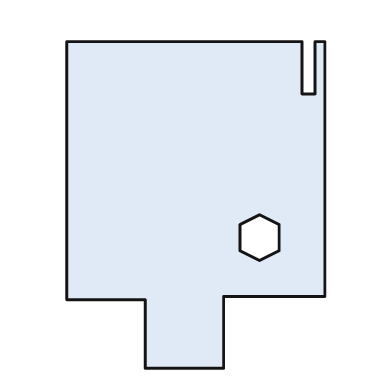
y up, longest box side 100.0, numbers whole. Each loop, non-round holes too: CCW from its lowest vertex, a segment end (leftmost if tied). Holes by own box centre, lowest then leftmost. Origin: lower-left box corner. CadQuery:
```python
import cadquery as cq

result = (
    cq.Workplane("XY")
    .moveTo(24.0, 0.0)
    .lineTo(48.0, 0.0)
    .lineTo(48.0, 22.0)
    .lineTo(79.0, 22.0)
    .lineTo(79.0, 100.0)
    .lineTo(76.0, 100.0)
    .lineTo(76.0, 84.0)
    .lineTo(72.0, 84.0)
    .lineTo(72.0, 100.0)
    .lineTo(0.0, 100.0)
    .lineTo(0.0, 21.0)
    .lineTo(24.0, 21.0)
    .close()
    .moveTo(59.0, 33.0)
    .lineTo(65.0, 36.0)
    .lineTo(65.0, 44.0)
    .lineTo(59.0, 47.0)
    .lineTo(53.0, 44.0)
    .lineTo(53.0, 36.0)
    .close()
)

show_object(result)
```